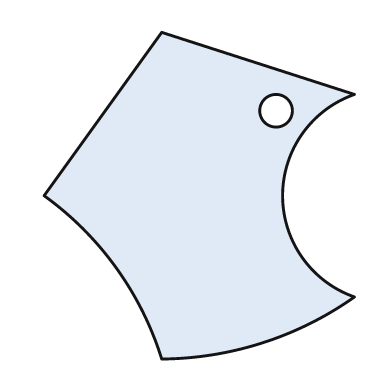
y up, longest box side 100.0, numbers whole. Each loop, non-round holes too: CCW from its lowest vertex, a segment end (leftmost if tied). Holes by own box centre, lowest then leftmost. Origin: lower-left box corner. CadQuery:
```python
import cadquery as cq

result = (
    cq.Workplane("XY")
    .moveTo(36.0, 0.0)
    .threePointArc((67.0, 5.0), (95.0, 19.0))
    .threePointArc((73.0, 50.0), (95.0, 81.0))
    .lineTo(36.0, 100.0)
    .lineTo(0.0, 50.0)
    .threePointArc((22.0, 28.0), (36.0, 0.0))
    .close()
    .moveTo(71.0, 76.0)
    .circle(5.0)
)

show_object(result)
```